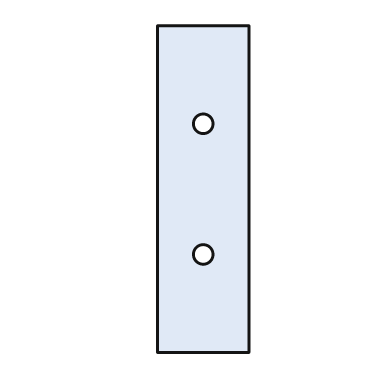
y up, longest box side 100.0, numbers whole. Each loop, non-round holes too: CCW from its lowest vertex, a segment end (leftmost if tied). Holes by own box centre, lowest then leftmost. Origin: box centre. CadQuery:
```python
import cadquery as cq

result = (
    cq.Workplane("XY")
    .moveTo(-14.0, -50.0)
    .lineTo(14.0, -50.0)
    .lineTo(14.0, 50.0)
    .lineTo(-14.0, 50.0)
    .close()
    .moveTo(0.0, -20.0)
    .circle(3.0)
    .moveTo(0.0, 20.0)
    .circle(3.0)
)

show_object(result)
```